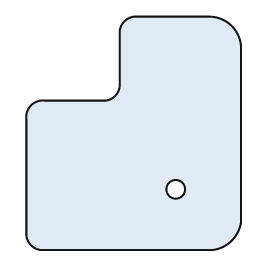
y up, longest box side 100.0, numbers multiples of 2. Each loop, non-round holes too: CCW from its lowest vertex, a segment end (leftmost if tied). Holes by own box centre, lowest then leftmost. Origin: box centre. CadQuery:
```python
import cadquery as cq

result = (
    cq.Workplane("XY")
    .moveTo(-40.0, -50.0)
    .lineTo(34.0, -50.0)
    .threePointArc((42.0, -46.0), (46.0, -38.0))
    .lineTo(46.0, 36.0)
    .threePointArc((42.0, 46.0), (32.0, 50.0))
    .lineTo(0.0, 50.0)
    .threePointArc((-4.0, 48.0), (-6.0, 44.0))
    .lineTo(-6.0, 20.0)
    .threePointArc((-8.0, 16.0), (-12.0, 14.0))
    .lineTo(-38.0, 14.0)
    .threePointArc((-44.0, 12.0), (-46.0, 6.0))
    .lineTo(-46.0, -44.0)
    .threePointArc((-44.0, -48.0), (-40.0, -50.0))
    .close()
    .moveTo(18.0, -24.0)
    .circle(4.0)
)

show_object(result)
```